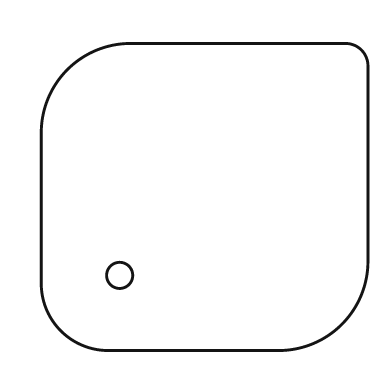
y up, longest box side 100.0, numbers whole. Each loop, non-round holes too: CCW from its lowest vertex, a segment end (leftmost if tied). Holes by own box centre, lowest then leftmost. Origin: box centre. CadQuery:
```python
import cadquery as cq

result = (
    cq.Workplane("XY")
    .moveTo(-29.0, -47.0)
    .lineTo(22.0, -47.0)
    .threePointArc((42.0, -39.0), (50.0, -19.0))
    .lineTo(50.0, 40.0)
    .threePointArc((48.0, 45.0), (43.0, 47.0))
    .lineTo(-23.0, 47.0)
    .threePointArc((-42.0, 39.0), (-50.0, 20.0))
    .lineTo(-50.0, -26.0)
    .threePointArc((-44.0, -41.0), (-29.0, -47.0))
    .close()
    .moveTo(-26.0, -24.0)
    .circle(4.0)
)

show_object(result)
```